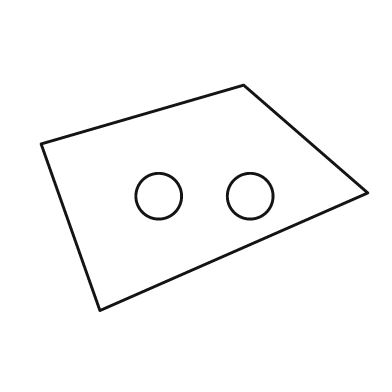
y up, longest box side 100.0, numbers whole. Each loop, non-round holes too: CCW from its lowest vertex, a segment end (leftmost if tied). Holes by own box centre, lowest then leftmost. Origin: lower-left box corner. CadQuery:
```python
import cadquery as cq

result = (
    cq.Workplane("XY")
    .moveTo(18.0, 0.0)
    .lineTo(100.0, 36.0)
    .lineTo(62.0, 69.0)
    .lineTo(0.0, 51.0)
    .close()
    .moveTo(36.0, 35.0)
    .circle(7.0)
    .moveTo(64.0, 35.0)
    .circle(7.0)
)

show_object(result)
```